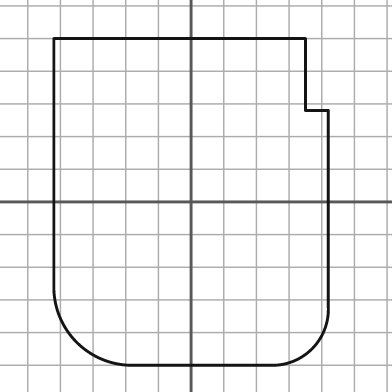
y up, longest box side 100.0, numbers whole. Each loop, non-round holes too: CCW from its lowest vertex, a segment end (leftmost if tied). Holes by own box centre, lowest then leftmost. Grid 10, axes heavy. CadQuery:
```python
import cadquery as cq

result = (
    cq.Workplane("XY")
    .moveTo(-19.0, -50.0)
    .lineTo(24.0, -50.0)
    .threePointArc((37.0, -45.0), (42.0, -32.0))
    .lineTo(42.0, 28.0)
    .lineTo(35.0, 28.0)
    .lineTo(35.0, 50.0)
    .lineTo(-42.0, 50.0)
    .lineTo(-42.0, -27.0)
    .threePointArc((-35.0, -43.0), (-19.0, -50.0))
    .close()
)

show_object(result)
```